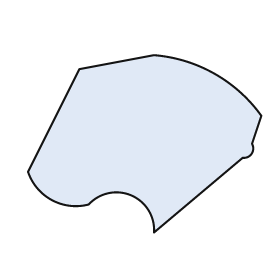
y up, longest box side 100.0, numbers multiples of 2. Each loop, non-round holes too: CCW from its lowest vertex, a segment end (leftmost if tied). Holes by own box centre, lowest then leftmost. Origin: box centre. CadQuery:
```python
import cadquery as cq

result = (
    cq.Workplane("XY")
    .moveTo(4.0, -38.0)
    .lineTo(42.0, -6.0)
    .threePointArc((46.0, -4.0), (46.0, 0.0))
    .lineTo(50.0, 12.0)
    .threePointArc((30.0, 30.0), (4.0, 38.0))
    .lineTo(-28.0, 32.0)
    .lineTo(-50.0, -12.0)
    .threePointArc((-40.0, -24.0), (-24.0, -26.0))
    .threePointArc((-6.0, -22.0), (4.0, -38.0))
    .close()
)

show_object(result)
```